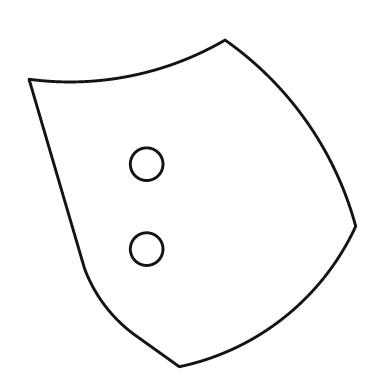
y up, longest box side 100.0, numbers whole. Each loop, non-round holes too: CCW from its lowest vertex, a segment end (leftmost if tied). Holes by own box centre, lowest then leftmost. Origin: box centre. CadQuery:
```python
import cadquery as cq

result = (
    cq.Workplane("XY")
    .moveTo(-4.0, -50.0)
    .threePointArc((28.0, -35.0), (50.0, -7.0))
    .threePointArc((35.0, 25.0), (10.0, 50.0))
    .threePointArc((-19.0, 39.0), (-50.0, 38.0))
    .lineTo(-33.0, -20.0)
    .threePointArc((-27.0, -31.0), (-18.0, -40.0))
    .close()
    .moveTo(-14.0, -14.0)
    .circle(5.0)
    .moveTo(-14.0, 12.0)
    .circle(5.0)
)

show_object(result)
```